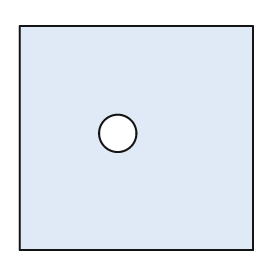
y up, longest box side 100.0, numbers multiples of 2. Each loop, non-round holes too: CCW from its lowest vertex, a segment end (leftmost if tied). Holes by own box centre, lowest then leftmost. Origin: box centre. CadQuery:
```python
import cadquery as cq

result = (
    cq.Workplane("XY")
    .moveTo(-50.0, -48.0)
    .lineTo(50.0, -48.0)
    .lineTo(50.0, 48.0)
    .lineTo(-50.0, 48.0)
    .close()
    .moveTo(-8.0, 2.0)
    .circle(8.0)
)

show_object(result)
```